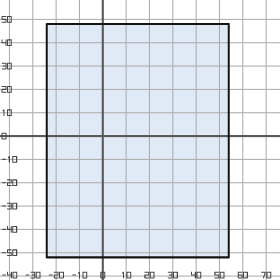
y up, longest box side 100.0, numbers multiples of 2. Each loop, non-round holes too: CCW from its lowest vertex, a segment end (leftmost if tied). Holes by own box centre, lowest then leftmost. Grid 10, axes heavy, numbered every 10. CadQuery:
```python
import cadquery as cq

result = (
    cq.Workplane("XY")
    .moveTo(-24.0, -52.0)
    .lineTo(54.0, -52.0)
    .lineTo(54.0, 48.0)
    .lineTo(-24.0, 48.0)
    .close()
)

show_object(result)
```